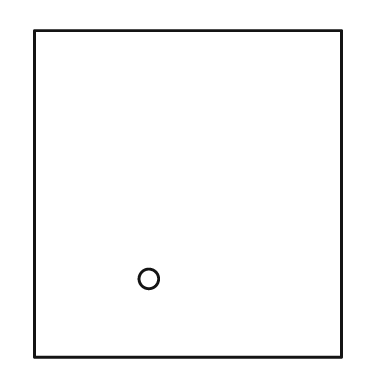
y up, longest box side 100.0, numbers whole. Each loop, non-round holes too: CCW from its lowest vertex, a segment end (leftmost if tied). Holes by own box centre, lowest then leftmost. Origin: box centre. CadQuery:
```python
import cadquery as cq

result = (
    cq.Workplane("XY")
    .moveTo(-47.0, -50.0)
    .lineTo(47.0, -50.0)
    .lineTo(47.0, 50.0)
    .lineTo(-47.0, 50.0)
    .close()
    .moveTo(-12.0, -26.0)
    .circle(3.0)
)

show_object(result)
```